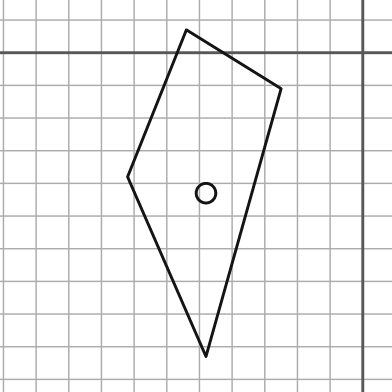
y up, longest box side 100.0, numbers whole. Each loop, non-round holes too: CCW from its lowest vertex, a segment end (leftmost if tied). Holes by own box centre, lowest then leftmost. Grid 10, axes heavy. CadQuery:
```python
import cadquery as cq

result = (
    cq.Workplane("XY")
    .moveTo(-48.0, -93.0)
    .lineTo(-25.0, -11.0)
    .lineTo(-54.0, 7.0)
    .lineTo(-72.0, -38.0)
    .close()
    .moveTo(-48.0, -43.0)
    .circle(3.0)
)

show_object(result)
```